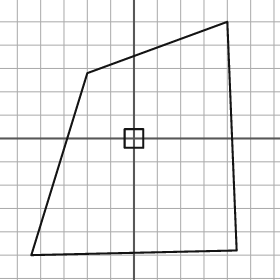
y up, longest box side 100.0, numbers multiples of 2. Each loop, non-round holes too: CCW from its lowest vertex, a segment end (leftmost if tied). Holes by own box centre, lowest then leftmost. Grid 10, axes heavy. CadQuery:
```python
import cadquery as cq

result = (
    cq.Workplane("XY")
    .moveTo(-44.0, -50.0)
    .lineTo(44.0, -48.0)
    .lineTo(40.0, 50.0)
    .lineTo(-20.0, 28.0)
    .close()
    .moveTo(-4.0, -4.0)
    .lineTo(4.0, -4.0)
    .lineTo(4.0, 4.0)
    .lineTo(-4.0, 4.0)
    .close()
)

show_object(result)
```